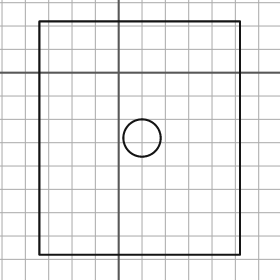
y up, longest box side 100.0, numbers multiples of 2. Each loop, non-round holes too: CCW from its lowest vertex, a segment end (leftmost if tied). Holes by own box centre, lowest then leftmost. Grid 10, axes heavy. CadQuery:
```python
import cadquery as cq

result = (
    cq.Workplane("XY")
    .moveTo(-34.0, -78.0)
    .lineTo(52.0, -78.0)
    .lineTo(52.0, 22.0)
    .lineTo(-34.0, 22.0)
    .close()
    .moveTo(10.0, -28.0)
    .circle(8.0)
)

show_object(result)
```